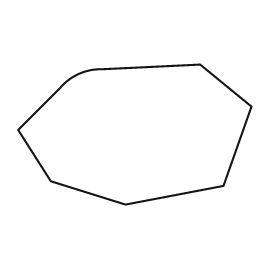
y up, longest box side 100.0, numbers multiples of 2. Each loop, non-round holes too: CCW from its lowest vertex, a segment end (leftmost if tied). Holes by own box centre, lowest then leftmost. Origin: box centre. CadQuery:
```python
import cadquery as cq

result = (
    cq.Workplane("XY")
    .moveTo(-4.0, -30.0)
    .lineTo(38.0, -22.0)
    .lineTo(50.0, 12.0)
    .lineTo(28.0, 30.0)
    .lineTo(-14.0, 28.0)
    .threePointArc((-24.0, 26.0), (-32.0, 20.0))
    .lineTo(-50.0, 2.0)
    .lineTo(-36.0, -20.0)
    .close()
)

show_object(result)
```